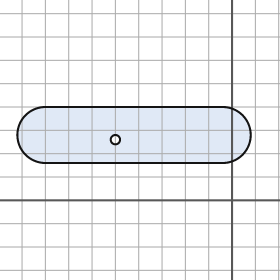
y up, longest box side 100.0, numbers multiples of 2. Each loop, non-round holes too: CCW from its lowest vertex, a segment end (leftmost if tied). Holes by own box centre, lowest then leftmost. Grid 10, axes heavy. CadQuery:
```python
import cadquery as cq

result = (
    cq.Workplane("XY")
    .moveTo(-80.0, 16.0)
    .lineTo(-4.0, 16.0)
    .threePointArc((8.0, 28.0), (-4.0, 40.0))
    .lineTo(-80.0, 40.0)
    .threePointArc((-92.0, 28.0), (-80.0, 16.0))
    .close()
    .moveTo(-50.0, 26.0)
    .circle(2.0)
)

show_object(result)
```